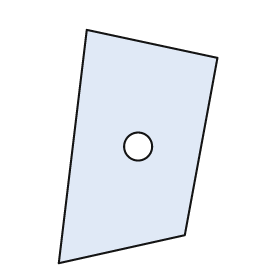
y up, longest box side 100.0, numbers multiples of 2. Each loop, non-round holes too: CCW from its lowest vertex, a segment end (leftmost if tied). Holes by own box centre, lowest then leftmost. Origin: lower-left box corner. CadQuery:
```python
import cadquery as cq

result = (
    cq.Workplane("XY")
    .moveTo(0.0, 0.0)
    .lineTo(54.0, 12.0)
    .lineTo(68.0, 88.0)
    .lineTo(12.0, 100.0)
    .close()
    .moveTo(34.0, 50.0)
    .circle(6.0)
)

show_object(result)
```